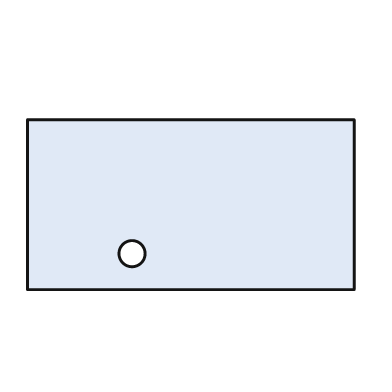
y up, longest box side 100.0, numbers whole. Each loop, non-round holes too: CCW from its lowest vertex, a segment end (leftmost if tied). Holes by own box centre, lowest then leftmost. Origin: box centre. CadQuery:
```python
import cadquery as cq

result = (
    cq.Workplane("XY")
    .moveTo(-50.0, -26.0)
    .lineTo(50.0, -26.0)
    .lineTo(50.0, 26.0)
    .lineTo(-50.0, 26.0)
    .close()
    .moveTo(-18.0, -15.0)
    .circle(4.0)
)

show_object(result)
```